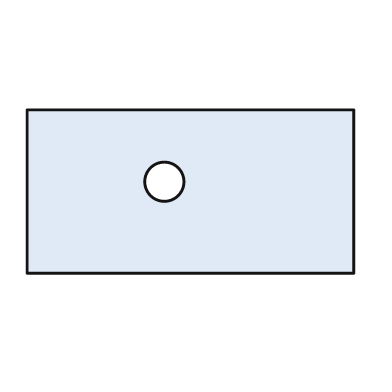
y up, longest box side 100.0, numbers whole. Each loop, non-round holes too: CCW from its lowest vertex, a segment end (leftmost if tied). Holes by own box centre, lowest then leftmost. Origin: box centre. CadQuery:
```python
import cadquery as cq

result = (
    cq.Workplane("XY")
    .moveTo(-50.0, -25.0)
    .lineTo(50.0, -25.0)
    .lineTo(50.0, 25.0)
    .lineTo(-50.0, 25.0)
    .close()
    .moveTo(-8.0, 3.0)
    .circle(6.0)
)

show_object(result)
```